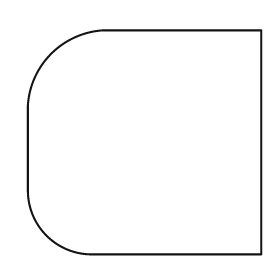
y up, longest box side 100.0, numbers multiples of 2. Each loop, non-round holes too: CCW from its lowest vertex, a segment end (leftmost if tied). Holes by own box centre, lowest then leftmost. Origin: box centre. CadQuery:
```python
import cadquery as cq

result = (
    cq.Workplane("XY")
    .moveTo(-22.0, -48.0)
    .lineTo(50.0, -48.0)
    .lineTo(50.0, 48.0)
    .lineTo(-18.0, 48.0)
    .threePointArc((-40.0, 38.0), (-50.0, 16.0))
    .lineTo(-50.0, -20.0)
    .threePointArc((-42.0, -40.0), (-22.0, -48.0))
    .close()
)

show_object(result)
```